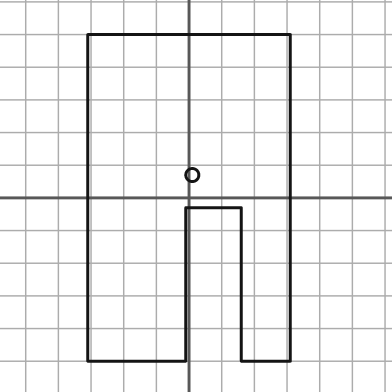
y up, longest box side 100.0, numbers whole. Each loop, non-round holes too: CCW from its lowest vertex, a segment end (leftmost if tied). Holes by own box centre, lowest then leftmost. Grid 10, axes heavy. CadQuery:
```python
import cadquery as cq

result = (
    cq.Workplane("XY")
    .moveTo(-31.0, -50.0)
    .lineTo(-1.0, -50.0)
    .lineTo(-1.0, -3.0)
    .lineTo(16.0, -3.0)
    .lineTo(16.0, -50.0)
    .lineTo(31.0, -50.0)
    .lineTo(31.0, 50.0)
    .lineTo(-31.0, 50.0)
    .close()
    .moveTo(1.0, 7.0)
    .circle(2.0)
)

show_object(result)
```